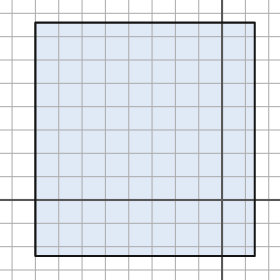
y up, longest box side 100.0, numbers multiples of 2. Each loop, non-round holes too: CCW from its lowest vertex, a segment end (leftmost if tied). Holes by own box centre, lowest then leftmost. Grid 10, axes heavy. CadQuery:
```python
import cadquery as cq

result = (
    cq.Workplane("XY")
    .moveTo(-80.0, -24.0)
    .lineTo(14.0, -24.0)
    .lineTo(14.0, 76.0)
    .lineTo(-80.0, 76.0)
    .close()
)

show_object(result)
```